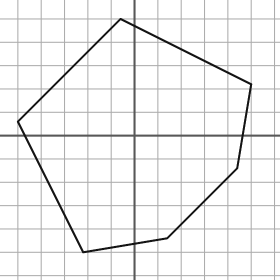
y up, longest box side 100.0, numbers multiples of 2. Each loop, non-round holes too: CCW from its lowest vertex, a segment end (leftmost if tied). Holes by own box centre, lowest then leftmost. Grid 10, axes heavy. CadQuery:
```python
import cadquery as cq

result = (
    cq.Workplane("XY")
    .moveTo(-22.0, -50.0)
    .lineTo(14.0, -44.0)
    .lineTo(44.0, -14.0)
    .lineTo(50.0, 22.0)
    .lineTo(-6.0, 50.0)
    .lineTo(-50.0, 6.0)
    .close()
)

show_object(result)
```